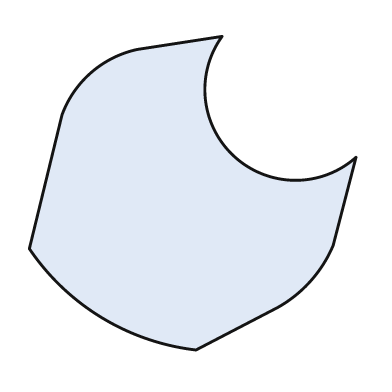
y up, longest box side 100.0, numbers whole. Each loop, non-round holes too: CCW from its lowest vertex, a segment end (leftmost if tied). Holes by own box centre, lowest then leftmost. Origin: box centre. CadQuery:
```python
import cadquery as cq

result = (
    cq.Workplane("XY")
    .moveTo(1.0, -48.0)
    .lineTo(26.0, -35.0)
    .threePointArc((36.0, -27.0), (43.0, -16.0))
    .lineTo(50.0, 11.0)
    .threePointArc((13.0, 11.0), (9.0, 48.0))
    .lineTo(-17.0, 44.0)
    .threePointArc((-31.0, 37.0), (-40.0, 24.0))
    .lineTo(-50.0, -17.0)
    .threePointArc((-28.0, -38.0), (1.0, -48.0))
    .close()
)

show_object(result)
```